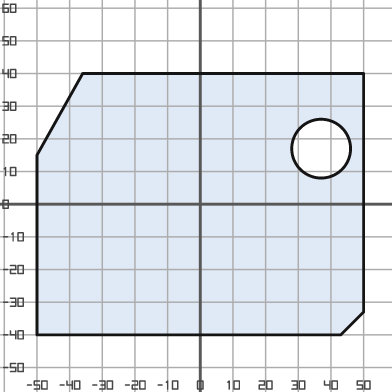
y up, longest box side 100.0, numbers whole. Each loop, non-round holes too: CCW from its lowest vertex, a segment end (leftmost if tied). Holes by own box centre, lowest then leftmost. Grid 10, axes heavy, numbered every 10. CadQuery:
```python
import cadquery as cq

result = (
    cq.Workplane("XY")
    .moveTo(-50.0, -40.0)
    .lineTo(43.0, -40.0)
    .lineTo(50.0, -33.0)
    .lineTo(50.0, 40.0)
    .lineTo(-36.0, 40.0)
    .lineTo(-50.0, 15.0)
    .close()
    .moveTo(37.0, 17.0)
    .circle(9.0)
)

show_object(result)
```